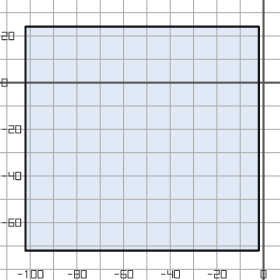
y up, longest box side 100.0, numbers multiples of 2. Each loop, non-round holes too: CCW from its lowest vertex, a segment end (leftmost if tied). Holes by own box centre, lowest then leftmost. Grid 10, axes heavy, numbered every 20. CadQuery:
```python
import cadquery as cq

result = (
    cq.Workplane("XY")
    .moveTo(-102.0, -72.0)
    .lineTo(-2.0, -72.0)
    .lineTo(-2.0, 24.0)
    .lineTo(-102.0, 24.0)
    .close()
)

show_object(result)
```